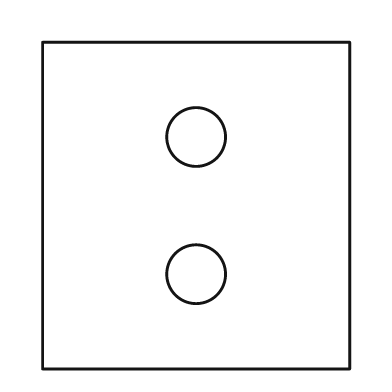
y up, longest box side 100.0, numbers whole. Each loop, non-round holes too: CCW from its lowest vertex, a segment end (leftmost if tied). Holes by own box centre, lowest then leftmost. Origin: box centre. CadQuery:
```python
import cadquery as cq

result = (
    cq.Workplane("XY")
    .moveTo(-47.0, -50.0)
    .lineTo(47.0, -50.0)
    .lineTo(47.0, 50.0)
    .lineTo(-47.0, 50.0)
    .close()
    .moveTo(0.0, -21.0)
    .circle(9.0)
    .moveTo(0.0, 21.0)
    .circle(9.0)
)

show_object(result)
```